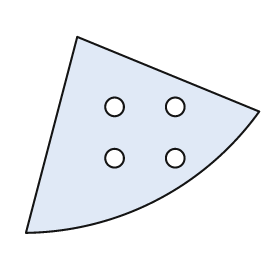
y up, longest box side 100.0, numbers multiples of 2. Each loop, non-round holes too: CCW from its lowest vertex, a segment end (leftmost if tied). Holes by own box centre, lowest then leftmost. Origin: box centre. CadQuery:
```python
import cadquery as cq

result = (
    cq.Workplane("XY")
    .moveTo(-50.0, -42.0)
    .threePointArc((6.0, -28.0), (50.0, 10.0))
    .lineTo(-28.0, 42.0)
    .close()
    .moveTo(-12.0, -10.0)
    .circle(4.0)
    .moveTo(14.0, -10.0)
    .circle(4.0)
    .moveTo(-12.0, 12.0)
    .circle(4.0)
    .moveTo(14.0, 12.0)
    .circle(4.0)
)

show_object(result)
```